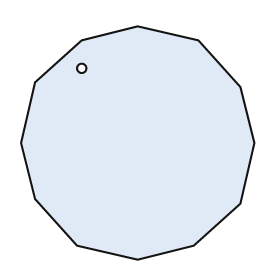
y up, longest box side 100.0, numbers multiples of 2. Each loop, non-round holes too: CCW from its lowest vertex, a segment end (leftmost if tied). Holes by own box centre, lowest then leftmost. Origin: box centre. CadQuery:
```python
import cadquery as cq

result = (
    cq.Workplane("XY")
    .moveTo(0.0, -50.0)
    .lineTo(24.0, -44.0)
    .lineTo(44.0, -26.0)
    .lineTo(50.0, 0.0)
    .lineTo(44.0, 24.0)
    .lineTo(26.0, 44.0)
    .lineTo(0.0, 50.0)
    .lineTo(-24.0, 44.0)
    .lineTo(-44.0, 26.0)
    .lineTo(-50.0, 0.0)
    .lineTo(-44.0, -24.0)
    .lineTo(-26.0, -44.0)
    .close()
    .moveTo(-24.0, 32.0)
    .circle(2.0)
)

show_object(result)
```